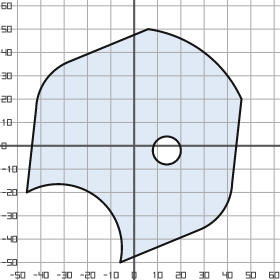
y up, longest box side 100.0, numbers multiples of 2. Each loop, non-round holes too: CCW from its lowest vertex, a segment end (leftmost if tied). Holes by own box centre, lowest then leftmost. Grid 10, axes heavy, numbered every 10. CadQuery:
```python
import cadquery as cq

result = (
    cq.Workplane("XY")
    .moveTo(-6.0, -50.0)
    .lineTo(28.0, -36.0)
    .threePointArc((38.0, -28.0), (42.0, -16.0))
    .lineTo(46.0, 20.0)
    .threePointArc((30.0, 40.0), (6.0, 50.0))
    .lineTo(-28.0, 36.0)
    .threePointArc((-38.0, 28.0), (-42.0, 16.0))
    .lineTo(-46.0, -20.0)
    .threePointArc((-16.0, -22.0), (-6.0, -50.0))
    .close()
    .moveTo(14.0, -2.0)
    .circle(6.0)
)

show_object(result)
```